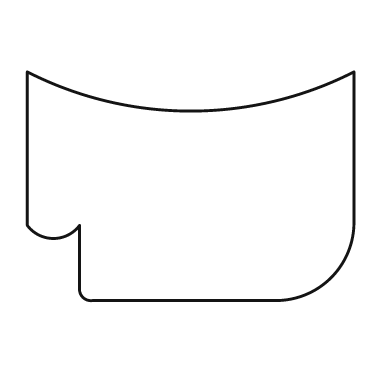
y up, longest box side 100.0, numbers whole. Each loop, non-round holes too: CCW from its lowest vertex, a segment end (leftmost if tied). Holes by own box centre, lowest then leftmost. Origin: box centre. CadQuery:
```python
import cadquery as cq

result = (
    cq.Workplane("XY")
    .moveTo(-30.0, -35.0)
    .lineTo(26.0, -35.0)
    .threePointArc((43.0, -28.0), (50.0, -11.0))
    .lineTo(50.0, 35.0)
    .threePointArc((0.0, 23.0), (-50.0, 35.0))
    .lineTo(-50.0, -12.0)
    .threePointArc((-42.0, -16.0), (-34.0, -12.0))
    .lineTo(-34.0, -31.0)
    .threePointArc((-33.0, -34.0), (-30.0, -35.0))
    .close()
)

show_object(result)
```